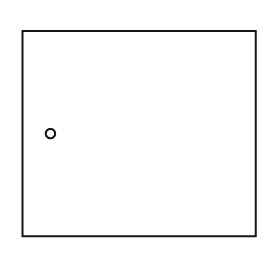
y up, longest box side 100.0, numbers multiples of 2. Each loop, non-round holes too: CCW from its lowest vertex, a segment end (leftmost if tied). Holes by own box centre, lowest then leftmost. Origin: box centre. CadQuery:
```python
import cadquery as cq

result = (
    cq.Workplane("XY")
    .moveTo(-50.0, -44.0)
    .lineTo(50.0, -44.0)
    .lineTo(50.0, 44.0)
    .lineTo(-50.0, 44.0)
    .close()
    .moveTo(-38.0, 0.0)
    .circle(2.0)
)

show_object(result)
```